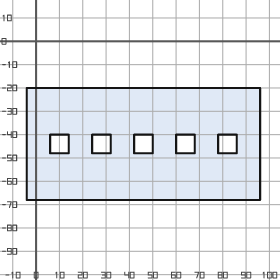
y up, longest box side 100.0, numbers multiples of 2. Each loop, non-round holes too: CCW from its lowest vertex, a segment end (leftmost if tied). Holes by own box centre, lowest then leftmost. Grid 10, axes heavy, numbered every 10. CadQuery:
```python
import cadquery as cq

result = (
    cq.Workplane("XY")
    .moveTo(-4.0, -68.0)
    .lineTo(96.0, -68.0)
    .lineTo(96.0, -20.0)
    .lineTo(-4.0, -20.0)
    .close()
    .moveTo(6.0, -48.0)
    .lineTo(14.0, -48.0)
    .lineTo(14.0, -40.0)
    .lineTo(6.0, -40.0)
    .close()
    .moveTo(24.0, -48.0)
    .lineTo(32.0, -48.0)
    .lineTo(32.0, -40.0)
    .lineTo(24.0, -40.0)
    .close()
    .moveTo(42.0, -48.0)
    .lineTo(50.0, -48.0)
    .lineTo(50.0, -40.0)
    .lineTo(42.0, -40.0)
    .close()
    .moveTo(60.0, -48.0)
    .lineTo(68.0, -48.0)
    .lineTo(68.0, -40.0)
    .lineTo(60.0, -40.0)
    .close()
    .moveTo(78.0, -48.0)
    .lineTo(86.0, -48.0)
    .lineTo(86.0, -40.0)
    .lineTo(78.0, -40.0)
    .close()
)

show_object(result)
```